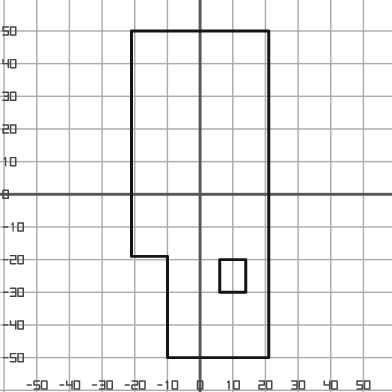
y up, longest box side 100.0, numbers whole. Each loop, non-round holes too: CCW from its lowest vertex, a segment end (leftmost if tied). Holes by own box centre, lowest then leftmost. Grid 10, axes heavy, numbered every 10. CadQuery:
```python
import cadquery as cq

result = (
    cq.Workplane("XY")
    .moveTo(-10.0, -50.0)
    .lineTo(21.0, -50.0)
    .lineTo(21.0, 50.0)
    .lineTo(-21.0, 50.0)
    .lineTo(-21.0, -19.0)
    .lineTo(-10.0, -19.0)
    .close()
    .moveTo(6.0, -30.0)
    .lineTo(14.0, -30.0)
    .lineTo(14.0, -20.0)
    .lineTo(6.0, -20.0)
    .close()
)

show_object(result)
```